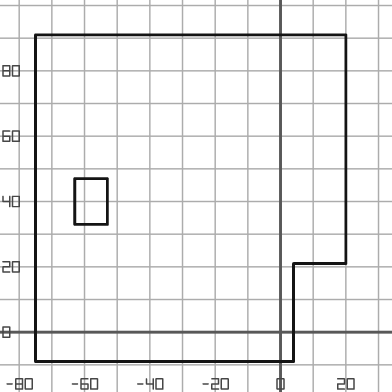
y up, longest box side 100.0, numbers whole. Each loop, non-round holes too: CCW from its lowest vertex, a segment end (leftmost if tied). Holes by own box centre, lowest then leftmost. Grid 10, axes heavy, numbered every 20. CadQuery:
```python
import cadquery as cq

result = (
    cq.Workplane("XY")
    .moveTo(-75.0, -9.0)
    .lineTo(4.0, -9.0)
    .lineTo(4.0, 21.0)
    .lineTo(20.0, 21.0)
    .lineTo(20.0, 91.0)
    .lineTo(-75.0, 91.0)
    .close()
    .moveTo(-63.0, 33.0)
    .lineTo(-53.0, 33.0)
    .lineTo(-53.0, 47.0)
    .lineTo(-63.0, 47.0)
    .close()
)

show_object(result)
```